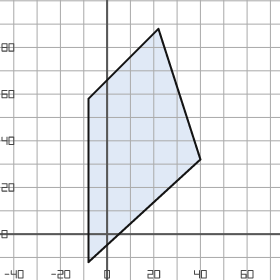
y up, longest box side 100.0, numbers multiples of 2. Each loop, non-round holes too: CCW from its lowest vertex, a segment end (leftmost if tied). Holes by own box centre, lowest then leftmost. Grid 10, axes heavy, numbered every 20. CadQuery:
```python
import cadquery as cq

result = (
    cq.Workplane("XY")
    .moveTo(-8.0, -12.0)
    .lineTo(40.0, 32.0)
    .lineTo(22.0, 88.0)
    .lineTo(-8.0, 58.0)
    .close()
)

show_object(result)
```